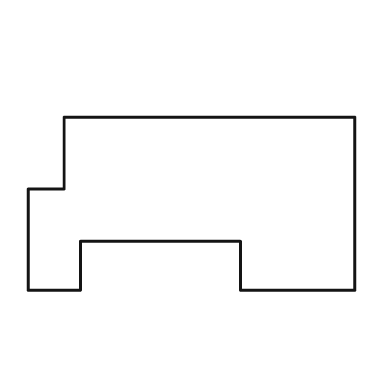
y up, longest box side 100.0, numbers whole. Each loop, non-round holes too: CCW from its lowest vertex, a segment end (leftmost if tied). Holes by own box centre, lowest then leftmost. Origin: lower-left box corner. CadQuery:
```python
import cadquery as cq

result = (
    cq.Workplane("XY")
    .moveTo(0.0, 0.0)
    .lineTo(16.0, 0.0)
    .lineTo(16.0, 15.0)
    .lineTo(65.0, 15.0)
    .lineTo(65.0, 0.0)
    .lineTo(100.0, 0.0)
    .lineTo(100.0, 53.0)
    .lineTo(11.0, 53.0)
    .lineTo(11.0, 31.0)
    .lineTo(0.0, 31.0)
    .close()
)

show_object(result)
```